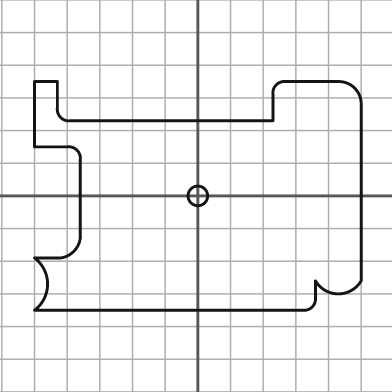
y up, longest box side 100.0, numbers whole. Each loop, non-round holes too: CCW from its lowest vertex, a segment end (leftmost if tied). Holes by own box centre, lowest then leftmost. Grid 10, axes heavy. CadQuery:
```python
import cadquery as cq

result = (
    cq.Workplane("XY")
    .moveTo(-50.0, -35.0)
    .lineTo(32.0, -35.0)
    .threePointArc((35.0, -34.0), (36.0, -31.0))
    .lineTo(36.0, -26.0)
    .threePointArc((43.0, -30.0), (50.0, -26.0))
    .lineTo(50.0, 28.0)
    .threePointArc((48.0, 33.0), (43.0, 35.0))
    .lineTo(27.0, 35.0)
    .threePointArc((24.0, 34.0), (23.0, 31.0))
    .lineTo(23.0, 23.0)
    .lineTo(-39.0, 23.0)
    .threePointArc((-42.0, 24.0), (-43.0, 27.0))
    .lineTo(-43.0, 35.0)
    .lineTo(-50.0, 35.0)
    .lineTo(-50.0, 15.0)
    .lineTo(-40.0, 15.0)
    .threePointArc((-37.0, 14.0), (-36.0, 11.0))
    .lineTo(-36.0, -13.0)
    .threePointArc((-38.0, -17.0), (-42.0, -19.0))
    .lineTo(-50.0, -19.0)
    .threePointArc((-46.0, -27.0), (-50.0, -35.0))
    .close()
    .moveTo(0.0, 0.0)
    .circle(3.0)
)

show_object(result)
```